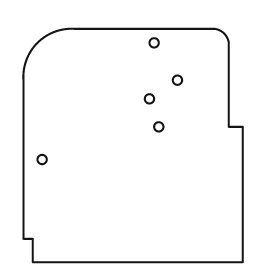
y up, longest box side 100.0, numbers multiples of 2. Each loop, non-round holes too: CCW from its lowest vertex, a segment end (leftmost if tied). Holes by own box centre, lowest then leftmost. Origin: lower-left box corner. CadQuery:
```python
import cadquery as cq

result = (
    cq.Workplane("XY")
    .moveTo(4.0, 0.0)
    .lineTo(94.0, 0.0)
    .lineTo(94.0, 58.0)
    .lineTo(88.0, 58.0)
    .lineTo(88.0, 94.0)
    .threePointArc((86.0, 98.0), (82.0, 100.0))
    .lineTo(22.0, 100.0)
    .threePointArc((6.0, 94.0), (0.0, 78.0))
    .lineTo(0.0, 10.0)
    .lineTo(4.0, 10.0)
    .close()
    .moveTo(8.0, 44.0)
    .circle(2.0)
    .moveTo(58.0, 58.0)
    .circle(2.0)
    .moveTo(54.0, 70.0)
    .circle(2.0)
    .moveTo(66.0, 78.0)
    .circle(2.0)
    .moveTo(56.0, 94.0)
    .circle(2.0)
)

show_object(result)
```